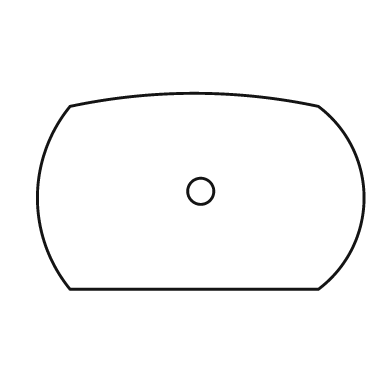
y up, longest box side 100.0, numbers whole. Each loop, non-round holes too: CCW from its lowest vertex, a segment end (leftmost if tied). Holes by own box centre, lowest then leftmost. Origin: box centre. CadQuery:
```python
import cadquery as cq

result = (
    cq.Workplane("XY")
    .moveTo(-40.0, -30.0)
    .lineTo(36.0, -30.0)
    .threePointArc((50.0, -2.0), (36.0, 26.0))
    .threePointArc((-2.0, 30.0), (-40.0, 26.0))
    .threePointArc((-50.0, -2.0), (-40.0, -30.0))
    .close()
    .moveTo(0.0, 0.0)
    .circle(4.0)
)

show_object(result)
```